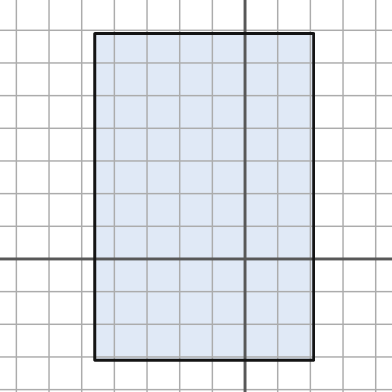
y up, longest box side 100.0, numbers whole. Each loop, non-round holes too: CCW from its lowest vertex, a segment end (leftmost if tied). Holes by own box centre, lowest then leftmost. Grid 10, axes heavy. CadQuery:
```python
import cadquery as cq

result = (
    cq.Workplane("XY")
    .moveTo(-46.0, -31.0)
    .lineTo(21.0, -31.0)
    .lineTo(21.0, 69.0)
    .lineTo(-46.0, 69.0)
    .close()
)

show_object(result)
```